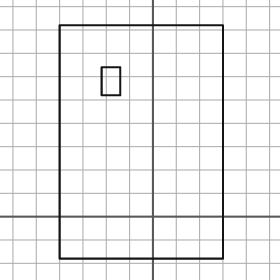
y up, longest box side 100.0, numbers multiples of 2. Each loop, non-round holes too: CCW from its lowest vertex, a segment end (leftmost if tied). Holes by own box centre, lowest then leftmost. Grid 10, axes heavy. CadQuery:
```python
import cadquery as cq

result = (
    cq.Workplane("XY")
    .moveTo(-40.0, -18.0)
    .lineTo(30.0, -18.0)
    .lineTo(30.0, 82.0)
    .lineTo(-40.0, 82.0)
    .close()
    .moveTo(-22.0, 52.0)
    .lineTo(-14.0, 52.0)
    .lineTo(-14.0, 64.0)
    .lineTo(-22.0, 64.0)
    .close()
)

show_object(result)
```